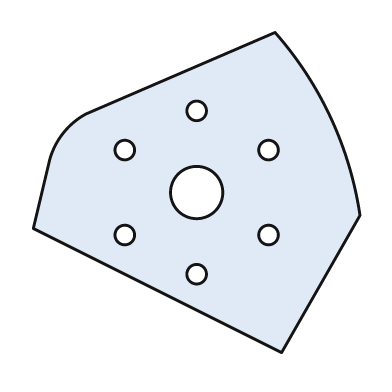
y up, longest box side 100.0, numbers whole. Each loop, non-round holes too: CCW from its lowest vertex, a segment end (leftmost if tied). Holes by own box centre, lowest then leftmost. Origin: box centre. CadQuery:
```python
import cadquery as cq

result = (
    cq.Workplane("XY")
    .moveTo(26.0, -49.0)
    .lineTo(50.0, -7.0)
    .threePointArc((41.0, 23.0), (24.0, 49.0))
    .lineTo(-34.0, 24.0)
    .threePointArc((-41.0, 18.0), (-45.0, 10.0))
    .lineTo(-50.0, -11.0)
    .close()
    .moveTo(0.0, -25.0)
    .circle(3.0)
    .moveTo(-22.0, -13.0)
    .circle(3.0)
    .moveTo(22.0, -13.0)
    .circle(3.0)
    .moveTo(0.0, 0.0)
    .circle(8.0)
    .moveTo(-22.0, 13.0)
    .circle(3.0)
    .moveTo(22.0, 13.0)
    .circle(3.0)
    .moveTo(0.0, 25.0)
    .circle(3.0)
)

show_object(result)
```